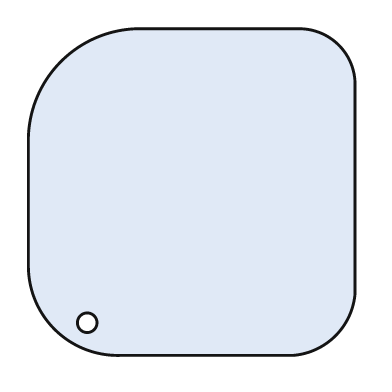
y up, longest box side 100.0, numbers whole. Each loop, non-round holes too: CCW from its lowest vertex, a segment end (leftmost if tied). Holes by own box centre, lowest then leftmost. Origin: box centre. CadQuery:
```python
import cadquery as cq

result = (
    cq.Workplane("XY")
    .moveTo(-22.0, -50.0)
    .lineTo(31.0, -50.0)
    .threePointArc((44.0, -44.0), (50.0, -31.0))
    .lineTo(50.0, 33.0)
    .threePointArc((45.0, 45.0), (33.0, 50.0))
    .lineTo(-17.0, 50.0)
    .threePointArc((-40.0, 40.0), (-50.0, 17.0))
    .lineTo(-50.0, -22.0)
    .threePointArc((-42.0, -42.0), (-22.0, -50.0))
    .close()
    .moveTo(-32.0, -40.0)
    .circle(3.0)
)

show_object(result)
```